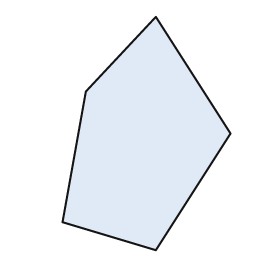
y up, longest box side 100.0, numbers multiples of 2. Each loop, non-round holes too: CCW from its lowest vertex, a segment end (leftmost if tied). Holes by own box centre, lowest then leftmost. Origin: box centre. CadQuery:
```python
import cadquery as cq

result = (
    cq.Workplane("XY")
    .moveTo(4.0, -50.0)
    .lineTo(36.0, 0.0)
    .lineTo(4.0, 50.0)
    .lineTo(-26.0, 18.0)
    .lineTo(-36.0, -38.0)
    .close()
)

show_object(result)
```